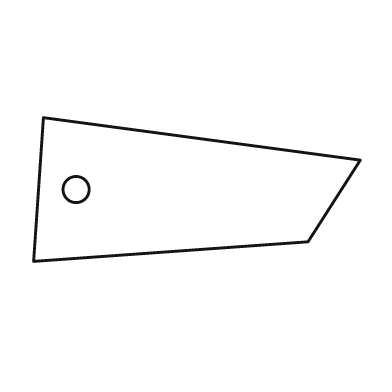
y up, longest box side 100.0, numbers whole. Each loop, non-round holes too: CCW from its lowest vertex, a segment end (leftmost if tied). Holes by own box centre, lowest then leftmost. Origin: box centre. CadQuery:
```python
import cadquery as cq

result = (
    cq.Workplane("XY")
    .moveTo(-50.0, -22.0)
    .lineTo(34.0, -16.0)
    .lineTo(50.0, 9.0)
    .lineTo(-47.0, 22.0)
    .close()
    .moveTo(-37.0, 0.0)
    .circle(4.0)
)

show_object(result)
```